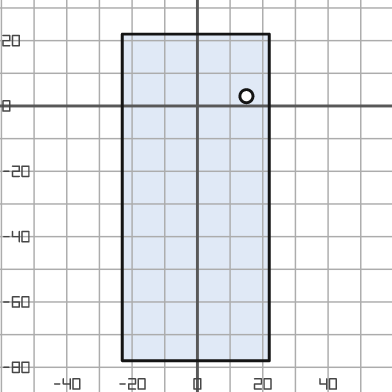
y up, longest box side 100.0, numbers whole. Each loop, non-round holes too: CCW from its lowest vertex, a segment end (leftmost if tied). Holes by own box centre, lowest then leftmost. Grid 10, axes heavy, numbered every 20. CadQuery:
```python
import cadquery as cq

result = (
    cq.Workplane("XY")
    .moveTo(-23.0, -78.0)
    .lineTo(22.0, -78.0)
    .lineTo(22.0, 22.0)
    .lineTo(-23.0, 22.0)
    .close()
    .moveTo(15.0, 3.0)
    .circle(2.0)
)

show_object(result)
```